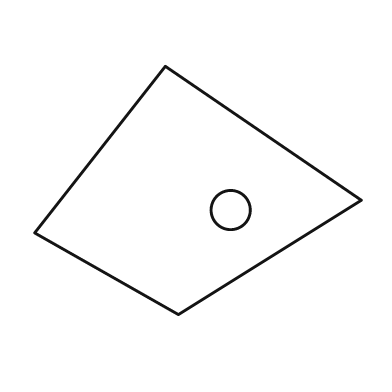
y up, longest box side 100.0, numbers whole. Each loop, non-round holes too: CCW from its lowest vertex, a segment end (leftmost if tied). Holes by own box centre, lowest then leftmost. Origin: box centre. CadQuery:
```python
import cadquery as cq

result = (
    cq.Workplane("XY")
    .moveTo(-6.0, -38.0)
    .lineTo(50.0, -3.0)
    .lineTo(-10.0, 38.0)
    .lineTo(-50.0, -13.0)
    .close()
    .moveTo(10.0, -6.0)
    .circle(6.0)
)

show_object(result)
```